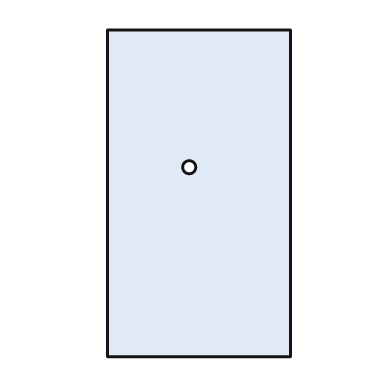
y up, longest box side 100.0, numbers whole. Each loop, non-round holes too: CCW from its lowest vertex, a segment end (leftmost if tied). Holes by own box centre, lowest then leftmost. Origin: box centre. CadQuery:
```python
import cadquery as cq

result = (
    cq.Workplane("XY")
    .moveTo(-28.0, -50.0)
    .lineTo(28.0, -50.0)
    .lineTo(28.0, 50.0)
    .lineTo(-28.0, 50.0)
    .close()
    .moveTo(-3.0, 8.0)
    .circle(2.0)
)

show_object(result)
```